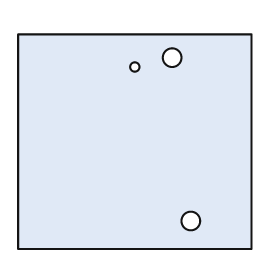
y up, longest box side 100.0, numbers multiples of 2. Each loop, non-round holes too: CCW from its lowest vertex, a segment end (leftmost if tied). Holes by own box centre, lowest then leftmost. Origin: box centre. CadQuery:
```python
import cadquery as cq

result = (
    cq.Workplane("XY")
    .moveTo(-50.0, -46.0)
    .lineTo(50.0, -46.0)
    .lineTo(50.0, 46.0)
    .lineTo(-50.0, 46.0)
    .close()
    .moveTo(24.0, -34.0)
    .circle(4.0)
    .moveTo(0.0, 32.0)
    .circle(2.0)
    .moveTo(16.0, 36.0)
    .circle(4.0)
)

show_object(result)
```